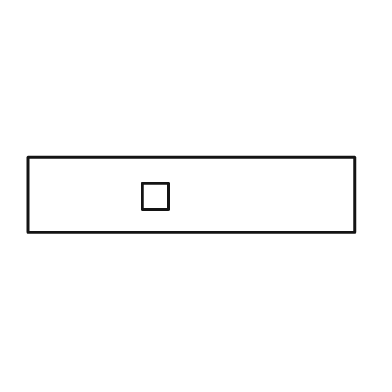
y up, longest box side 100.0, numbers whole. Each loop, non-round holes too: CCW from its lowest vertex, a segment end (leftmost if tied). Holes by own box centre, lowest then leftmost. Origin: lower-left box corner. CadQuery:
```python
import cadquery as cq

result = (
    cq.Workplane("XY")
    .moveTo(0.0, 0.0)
    .lineTo(100.0, 0.0)
    .lineTo(100.0, 23.0)
    .lineTo(0.0, 23.0)
    .close()
    .moveTo(35.0, 7.0)
    .lineTo(43.0, 7.0)
    .lineTo(43.0, 15.0)
    .lineTo(35.0, 15.0)
    .close()
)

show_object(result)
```